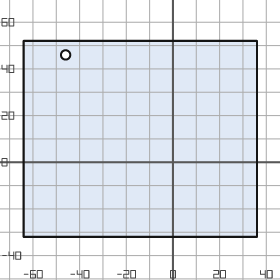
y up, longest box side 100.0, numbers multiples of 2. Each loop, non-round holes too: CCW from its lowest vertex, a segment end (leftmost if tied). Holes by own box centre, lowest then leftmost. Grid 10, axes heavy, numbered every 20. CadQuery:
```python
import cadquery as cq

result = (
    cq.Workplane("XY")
    .moveTo(-64.0, -32.0)
    .lineTo(36.0, -32.0)
    .lineTo(36.0, 52.0)
    .lineTo(-64.0, 52.0)
    .close()
    .moveTo(-46.0, 46.0)
    .circle(2.0)
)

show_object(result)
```